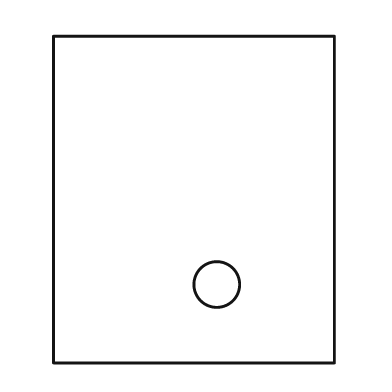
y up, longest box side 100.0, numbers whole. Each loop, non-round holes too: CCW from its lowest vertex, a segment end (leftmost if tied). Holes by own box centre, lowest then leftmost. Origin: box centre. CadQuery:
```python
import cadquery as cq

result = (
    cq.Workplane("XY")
    .moveTo(-43.0, -50.0)
    .lineTo(43.0, -50.0)
    .lineTo(43.0, 50.0)
    .lineTo(-43.0, 50.0)
    .close()
    .moveTo(7.0, -26.0)
    .circle(7.0)
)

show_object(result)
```